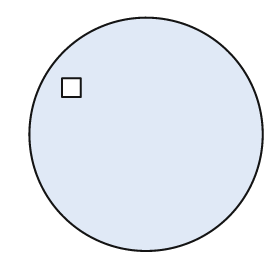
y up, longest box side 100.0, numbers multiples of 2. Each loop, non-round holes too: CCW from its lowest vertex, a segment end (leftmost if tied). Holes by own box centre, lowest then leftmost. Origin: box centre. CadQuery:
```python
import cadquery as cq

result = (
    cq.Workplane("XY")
    .moveTo(0.0, 0.0)
    .circle(50.0)
    .moveTo(-36.0, 16.0)
    .lineTo(-28.0, 16.0)
    .lineTo(-28.0, 24.0)
    .lineTo(-36.0, 24.0)
    .close()
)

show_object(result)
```